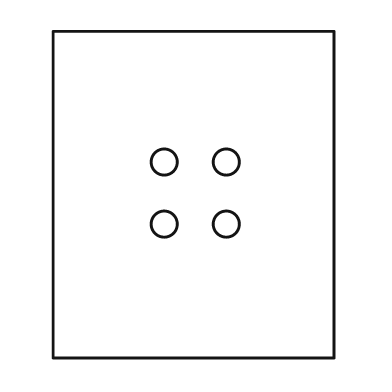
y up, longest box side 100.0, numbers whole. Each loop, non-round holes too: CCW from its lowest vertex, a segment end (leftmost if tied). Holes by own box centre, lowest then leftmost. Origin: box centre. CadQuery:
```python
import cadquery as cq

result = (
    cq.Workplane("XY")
    .moveTo(-43.0, -50.0)
    .lineTo(43.0, -50.0)
    .lineTo(43.0, 50.0)
    .lineTo(-43.0, 50.0)
    .close()
    .moveTo(-9.0, -9.0)
    .circle(4.0)
    .moveTo(10.0, -9.0)
    .circle(4.0)
    .moveTo(-9.0, 10.0)
    .circle(4.0)
    .moveTo(10.0, 10.0)
    .circle(4.0)
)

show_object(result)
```